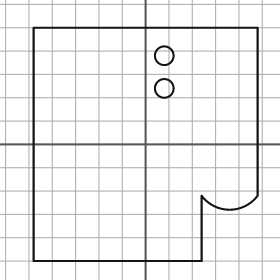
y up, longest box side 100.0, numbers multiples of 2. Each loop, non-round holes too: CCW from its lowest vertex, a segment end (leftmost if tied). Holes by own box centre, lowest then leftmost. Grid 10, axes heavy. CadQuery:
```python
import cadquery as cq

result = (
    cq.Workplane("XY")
    .moveTo(-48.0, -50.0)
    .lineTo(24.0, -50.0)
    .lineTo(24.0, -22.0)
    .threePointArc((36.0, -28.0), (48.0, -22.0))
    .lineTo(48.0, 50.0)
    .lineTo(-48.0, 50.0)
    .close()
    .moveTo(8.0, 24.0)
    .circle(4.0)
    .moveTo(8.0, 38.0)
    .circle(4.0)
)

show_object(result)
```